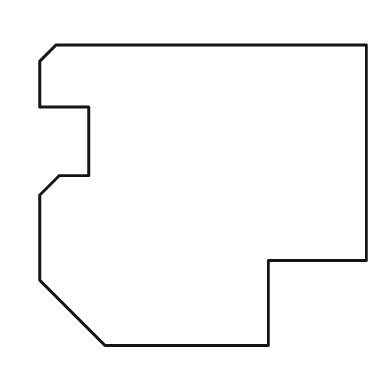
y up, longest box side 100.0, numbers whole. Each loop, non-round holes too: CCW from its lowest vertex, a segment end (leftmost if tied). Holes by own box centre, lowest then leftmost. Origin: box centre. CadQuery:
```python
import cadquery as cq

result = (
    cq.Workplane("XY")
    .moveTo(-30.0, -46.0)
    .lineTo(20.0, -46.0)
    .lineTo(20.0, -20.0)
    .lineTo(50.0, -20.0)
    .lineTo(50.0, 46.0)
    .lineTo(-45.0, 46.0)
    .lineTo(-50.0, 41.0)
    .lineTo(-50.0, 27.0)
    .lineTo(-35.0, 27.0)
    .lineTo(-35.0, 6.0)
    .lineTo(-44.0, 6.0)
    .lineTo(-50.0, 0.0)
    .lineTo(-50.0, -26.0)
    .close()
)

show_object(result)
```